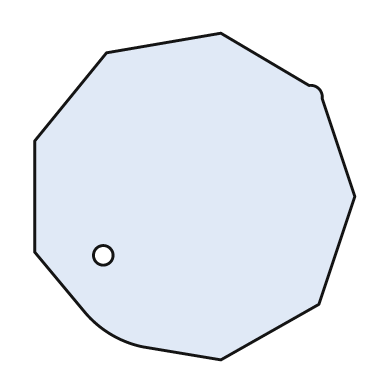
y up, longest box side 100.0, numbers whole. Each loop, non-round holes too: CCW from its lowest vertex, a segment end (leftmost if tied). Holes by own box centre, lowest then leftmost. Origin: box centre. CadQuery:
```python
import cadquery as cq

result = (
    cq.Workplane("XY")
    .moveTo(8.0, -50.0)
    .lineTo(38.0, -33.0)
    .lineTo(49.0, 0.0)
    .lineTo(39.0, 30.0)
    .threePointArc((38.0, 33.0), (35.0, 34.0))
    .lineTo(8.0, 50.0)
    .lineTo(-27.0, 44.0)
    .lineTo(-49.0, 17.0)
    .lineTo(-49.0, -17.0)
    .lineTo(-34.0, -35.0)
    .threePointArc((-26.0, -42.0), (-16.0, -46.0))
    .close()
    .moveTo(-28.0, -18.0)
    .circle(3.0)
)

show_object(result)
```